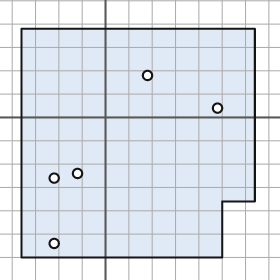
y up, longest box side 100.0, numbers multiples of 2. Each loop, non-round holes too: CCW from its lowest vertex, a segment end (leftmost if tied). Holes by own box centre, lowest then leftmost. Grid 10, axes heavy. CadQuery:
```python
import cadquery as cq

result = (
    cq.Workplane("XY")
    .moveTo(-36.0, -60.0)
    .lineTo(50.0, -60.0)
    .lineTo(50.0, -36.0)
    .lineTo(64.0, -36.0)
    .lineTo(64.0, 38.0)
    .lineTo(-36.0, 38.0)
    .close()
    .moveTo(-22.0, -54.0)
    .circle(2.0)
    .moveTo(-22.0, -26.0)
    .circle(2.0)
    .moveTo(-12.0, -24.0)
    .circle(2.0)
    .moveTo(48.0, 4.0)
    .circle(2.0)
    .moveTo(18.0, 18.0)
    .circle(2.0)
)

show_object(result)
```